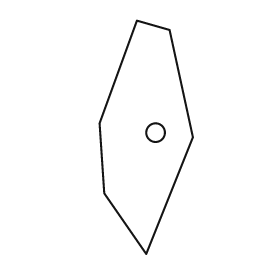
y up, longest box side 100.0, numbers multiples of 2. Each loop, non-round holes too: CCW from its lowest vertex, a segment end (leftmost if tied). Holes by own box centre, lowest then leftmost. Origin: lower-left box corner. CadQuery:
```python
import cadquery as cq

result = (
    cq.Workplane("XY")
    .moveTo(20.0, 0.0)
    .lineTo(40.0, 50.0)
    .lineTo(30.0, 96.0)
    .lineTo(16.0, 100.0)
    .lineTo(0.0, 56.0)
    .lineTo(2.0, 26.0)
    .close()
    .moveTo(24.0, 52.0)
    .circle(4.0)
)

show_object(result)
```